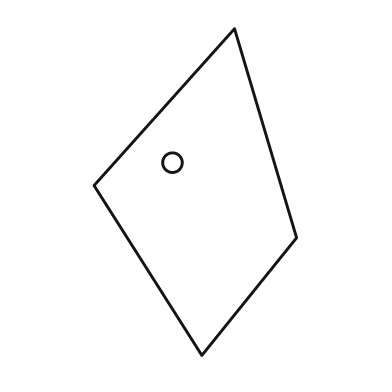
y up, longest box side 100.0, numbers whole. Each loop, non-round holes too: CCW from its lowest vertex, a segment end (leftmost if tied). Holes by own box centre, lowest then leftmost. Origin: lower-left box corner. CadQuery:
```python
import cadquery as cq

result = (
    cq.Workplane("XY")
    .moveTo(33.0, 0.0)
    .lineTo(62.0, 36.0)
    .lineTo(43.0, 100.0)
    .lineTo(0.0, 52.0)
    .close()
    .moveTo(24.0, 59.0)
    .circle(3.0)
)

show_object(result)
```